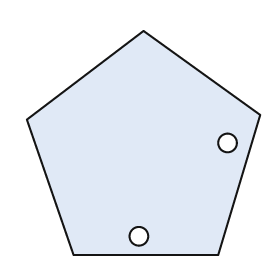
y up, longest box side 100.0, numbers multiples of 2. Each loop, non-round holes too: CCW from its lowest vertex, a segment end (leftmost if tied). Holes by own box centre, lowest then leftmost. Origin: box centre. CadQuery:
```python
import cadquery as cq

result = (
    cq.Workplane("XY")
    .moveTo(-30.0, -48.0)
    .lineTo(32.0, -48.0)
    .lineTo(50.0, 12.0)
    .lineTo(0.0, 48.0)
    .lineTo(-50.0, 10.0)
    .close()
    .moveTo(-2.0, -40.0)
    .circle(4.0)
    .moveTo(36.0, 0.0)
    .circle(4.0)
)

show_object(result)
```